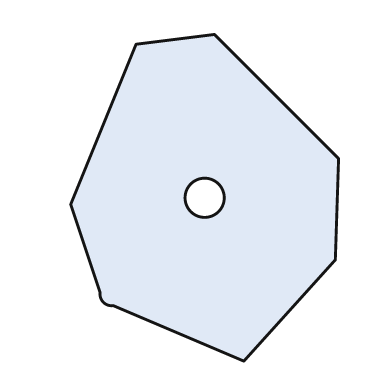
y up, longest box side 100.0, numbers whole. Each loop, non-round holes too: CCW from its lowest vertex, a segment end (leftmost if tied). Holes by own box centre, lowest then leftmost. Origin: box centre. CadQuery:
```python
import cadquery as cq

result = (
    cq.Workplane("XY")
    .moveTo(12.0, -50.0)
    .lineTo(40.0, -19.0)
    .lineTo(41.0, 12.0)
    .lineTo(3.0, 50.0)
    .lineTo(-21.0, 47.0)
    .lineTo(-41.0, -2.0)
    .lineTo(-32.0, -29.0)
    .threePointArc((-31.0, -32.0), (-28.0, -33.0))
    .close()
    .moveTo(0.0, 0.0)
    .circle(6.0)
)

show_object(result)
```